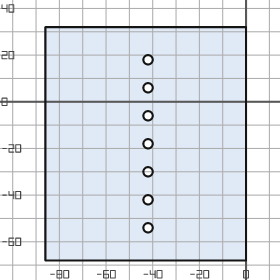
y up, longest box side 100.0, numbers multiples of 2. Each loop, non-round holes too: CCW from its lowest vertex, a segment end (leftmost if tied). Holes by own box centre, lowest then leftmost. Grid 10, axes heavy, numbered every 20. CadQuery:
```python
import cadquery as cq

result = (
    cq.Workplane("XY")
    .moveTo(-86.0, -68.0)
    .lineTo(0.0, -68.0)
    .lineTo(0.0, 32.0)
    .lineTo(-86.0, 32.0)
    .close()
    .moveTo(-42.0, -54.0)
    .circle(2.0)
    .moveTo(-42.0, -42.0)
    .circle(2.0)
    .moveTo(-42.0, -30.0)
    .circle(2.0)
    .moveTo(-42.0, -18.0)
    .circle(2.0)
    .moveTo(-42.0, -6.0)
    .circle(2.0)
    .moveTo(-42.0, 6.0)
    .circle(2.0)
    .moveTo(-42.0, 18.0)
    .circle(2.0)
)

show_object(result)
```